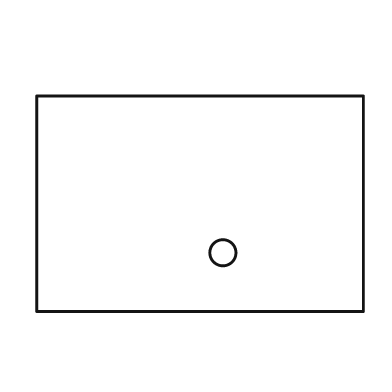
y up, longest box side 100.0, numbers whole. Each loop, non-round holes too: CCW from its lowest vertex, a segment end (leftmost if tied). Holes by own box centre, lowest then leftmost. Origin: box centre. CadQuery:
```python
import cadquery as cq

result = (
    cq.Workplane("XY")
    .moveTo(-50.0, -33.0)
    .lineTo(50.0, -33.0)
    .lineTo(50.0, 33.0)
    .lineTo(-50.0, 33.0)
    .close()
    .moveTo(7.0, -15.0)
    .circle(4.0)
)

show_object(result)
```